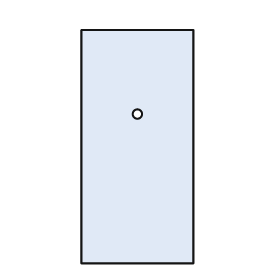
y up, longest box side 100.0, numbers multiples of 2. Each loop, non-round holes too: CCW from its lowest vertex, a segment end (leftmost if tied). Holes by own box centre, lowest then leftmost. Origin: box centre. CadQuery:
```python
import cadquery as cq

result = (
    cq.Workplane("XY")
    .moveTo(-24.0, -50.0)
    .lineTo(24.0, -50.0)
    .lineTo(24.0, 50.0)
    .lineTo(-24.0, 50.0)
    .close()
    .moveTo(0.0, 14.0)
    .circle(2.0)
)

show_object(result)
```